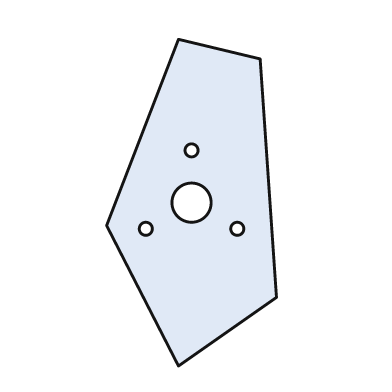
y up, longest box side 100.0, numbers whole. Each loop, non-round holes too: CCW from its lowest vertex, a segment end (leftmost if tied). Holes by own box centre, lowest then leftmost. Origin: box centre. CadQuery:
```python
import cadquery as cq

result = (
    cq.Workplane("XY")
    .moveTo(-4.0, -50.0)
    .lineTo(26.0, -29.0)
    .lineTo(21.0, 44.0)
    .lineTo(-4.0, 50.0)
    .lineTo(-26.0, -7.0)
    .close()
    .moveTo(-14.0, -8.0)
    .circle(2.0)
    .moveTo(14.0, -8.0)
    .circle(2.0)
    .moveTo(0.0, 0.0)
    .circle(6.0)
    .moveTo(0.0, 16.0)
    .circle(2.0)
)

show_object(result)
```